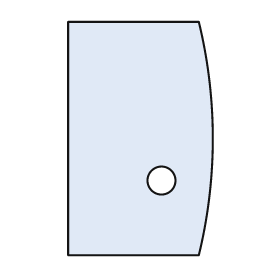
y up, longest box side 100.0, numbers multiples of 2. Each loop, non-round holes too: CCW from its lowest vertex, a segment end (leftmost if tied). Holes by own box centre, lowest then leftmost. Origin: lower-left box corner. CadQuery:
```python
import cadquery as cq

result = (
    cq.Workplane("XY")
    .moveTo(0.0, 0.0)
    .lineTo(56.0, 0.0)
    .threePointArc((62.0, 50.0), (56.0, 100.0))
    .lineTo(0.0, 100.0)
    .close()
    .moveTo(40.0, 32.0)
    .circle(6.0)
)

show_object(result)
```